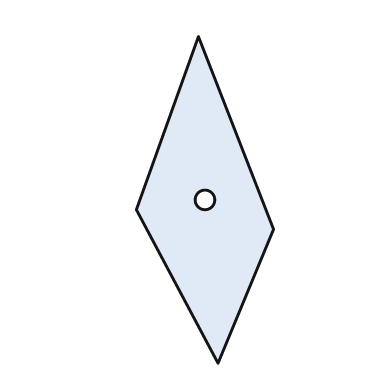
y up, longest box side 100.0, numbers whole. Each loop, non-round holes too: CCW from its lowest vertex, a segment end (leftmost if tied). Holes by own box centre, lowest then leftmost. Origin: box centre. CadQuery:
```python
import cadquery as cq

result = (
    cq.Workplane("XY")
    .moveTo(4.0, -50.0)
    .lineTo(21.0, -9.0)
    .lineTo(-2.0, 50.0)
    .lineTo(-21.0, -3.0)
    .close()
    .moveTo(0.0, 0.0)
    .circle(3.0)
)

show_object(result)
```